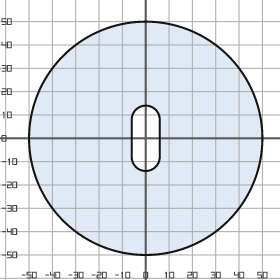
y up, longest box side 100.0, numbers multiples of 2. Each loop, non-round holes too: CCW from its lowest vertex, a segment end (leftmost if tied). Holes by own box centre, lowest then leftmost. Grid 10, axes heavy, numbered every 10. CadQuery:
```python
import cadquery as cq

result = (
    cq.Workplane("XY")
    .moveTo(0.0, 0.0)
    .circle(50.0)
    .moveTo(-6.0, -8.0)
    .threePointArc((0.0, -14.0), (6.0, -8.0))
    .lineTo(6.0, 8.0)
    .threePointArc((0.0, 14.0), (-6.0, 8.0))
    .close()
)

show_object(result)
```